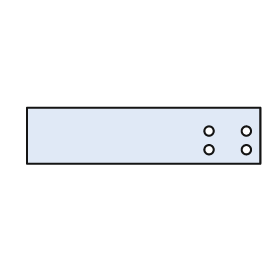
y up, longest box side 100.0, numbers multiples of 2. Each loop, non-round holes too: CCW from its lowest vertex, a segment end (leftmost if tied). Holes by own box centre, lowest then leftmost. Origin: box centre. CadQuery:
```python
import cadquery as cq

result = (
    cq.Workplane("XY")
    .moveTo(-50.0, -12.0)
    .lineTo(50.0, -12.0)
    .lineTo(50.0, 12.0)
    .lineTo(-50.0, 12.0)
    .close()
    .moveTo(28.0, -6.0)
    .circle(2.0)
    .moveTo(44.0, -6.0)
    .circle(2.0)
    .moveTo(28.0, 2.0)
    .circle(2.0)
    .moveTo(44.0, 2.0)
    .circle(2.0)
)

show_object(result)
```